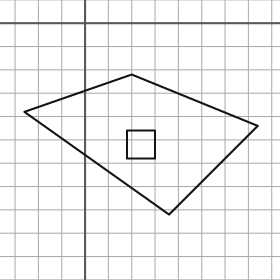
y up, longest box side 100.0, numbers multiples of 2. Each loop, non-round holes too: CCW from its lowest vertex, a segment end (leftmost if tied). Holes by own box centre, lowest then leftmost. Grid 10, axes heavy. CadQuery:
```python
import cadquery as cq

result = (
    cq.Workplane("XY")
    .moveTo(36.0, -82.0)
    .lineTo(74.0, -44.0)
    .lineTo(20.0, -22.0)
    .lineTo(-26.0, -38.0)
    .close()
    .moveTo(18.0, -58.0)
    .lineTo(30.0, -58.0)
    .lineTo(30.0, -46.0)
    .lineTo(18.0, -46.0)
    .close()
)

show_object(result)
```